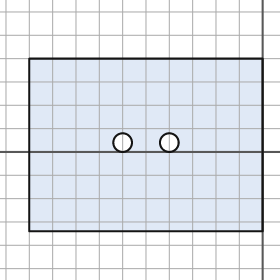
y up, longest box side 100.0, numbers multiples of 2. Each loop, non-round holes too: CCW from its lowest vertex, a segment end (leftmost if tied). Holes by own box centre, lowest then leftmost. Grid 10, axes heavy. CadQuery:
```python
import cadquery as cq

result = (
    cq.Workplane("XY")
    .moveTo(-100.0, -34.0)
    .lineTo(0.0, -34.0)
    .lineTo(0.0, 40.0)
    .lineTo(-100.0, 40.0)
    .close()
    .moveTo(-60.0, 4.0)
    .circle(4.0)
    .moveTo(-40.0, 4.0)
    .circle(4.0)
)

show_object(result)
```